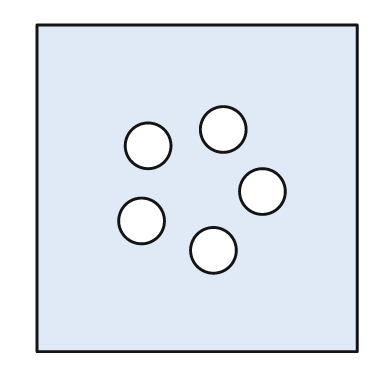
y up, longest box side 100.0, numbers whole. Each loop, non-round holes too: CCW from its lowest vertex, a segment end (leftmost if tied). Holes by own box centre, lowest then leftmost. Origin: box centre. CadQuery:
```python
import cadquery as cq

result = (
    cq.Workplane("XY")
    .moveTo(-49.0, -50.0)
    .lineTo(49.0, -50.0)
    .lineTo(49.0, 50.0)
    .lineTo(-49.0, 50.0)
    .close()
    .moveTo(5.0, -19.0)
    .circle(7.0)
    .moveTo(-17.0, -10.0)
    .circle(7.0)
    .moveTo(20.0, -1.0)
    .circle(7.0)
    .moveTo(-15.0, 13.0)
    .circle(7.0)
    .moveTo(8.0, 18.0)
    .circle(7.0)
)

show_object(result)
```